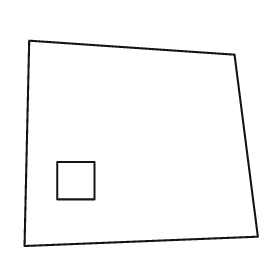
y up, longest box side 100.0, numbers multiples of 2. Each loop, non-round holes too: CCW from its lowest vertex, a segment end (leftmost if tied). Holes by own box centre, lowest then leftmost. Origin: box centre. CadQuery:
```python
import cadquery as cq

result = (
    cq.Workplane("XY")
    .moveTo(-50.0, -44.0)
    .lineTo(50.0, -40.0)
    .lineTo(40.0, 38.0)
    .lineTo(-48.0, 44.0)
    .close()
    .moveTo(-36.0, -24.0)
    .lineTo(-20.0, -24.0)
    .lineTo(-20.0, -8.0)
    .lineTo(-36.0, -8.0)
    .close()
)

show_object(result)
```